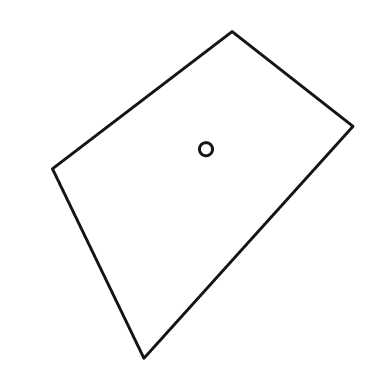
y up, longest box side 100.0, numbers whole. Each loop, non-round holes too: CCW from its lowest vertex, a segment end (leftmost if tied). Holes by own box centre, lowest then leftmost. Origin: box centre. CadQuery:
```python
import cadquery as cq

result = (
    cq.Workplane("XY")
    .moveTo(-18.0, -50.0)
    .lineTo(46.0, 21.0)
    .lineTo(9.0, 50.0)
    .lineTo(-46.0, 8.0)
    .close()
    .moveTo(1.0, 14.0)
    .circle(2.0)
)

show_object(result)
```